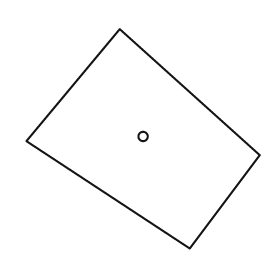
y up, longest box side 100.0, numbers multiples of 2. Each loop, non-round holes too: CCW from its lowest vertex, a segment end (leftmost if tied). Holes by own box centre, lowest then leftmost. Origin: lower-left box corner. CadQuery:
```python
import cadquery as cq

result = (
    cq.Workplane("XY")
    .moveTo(70.0, 0.0)
    .lineTo(100.0, 40.0)
    .lineTo(40.0, 94.0)
    .lineTo(0.0, 46.0)
    .close()
    .moveTo(50.0, 48.0)
    .circle(2.0)
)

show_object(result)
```